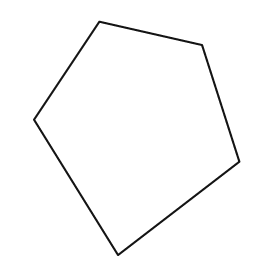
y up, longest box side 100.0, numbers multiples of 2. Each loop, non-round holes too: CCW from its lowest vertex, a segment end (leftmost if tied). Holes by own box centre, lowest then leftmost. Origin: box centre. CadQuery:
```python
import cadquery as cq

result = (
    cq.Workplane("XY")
    .moveTo(-8.0, -50.0)
    .lineTo(44.0, -10.0)
    .lineTo(28.0, 40.0)
    .lineTo(-16.0, 50.0)
    .lineTo(-44.0, 8.0)
    .close()
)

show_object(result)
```